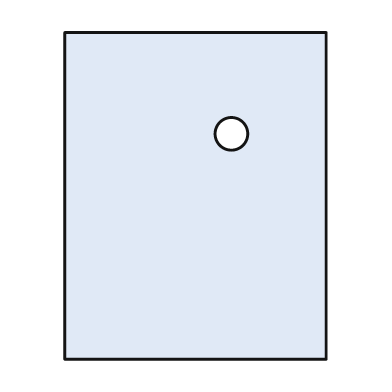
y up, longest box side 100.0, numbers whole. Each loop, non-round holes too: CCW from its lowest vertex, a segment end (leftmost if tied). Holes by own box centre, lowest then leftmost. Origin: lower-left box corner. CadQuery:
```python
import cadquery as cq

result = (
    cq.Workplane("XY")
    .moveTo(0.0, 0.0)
    .lineTo(80.0, 0.0)
    .lineTo(80.0, 100.0)
    .lineTo(0.0, 100.0)
    .close()
    .moveTo(51.0, 69.0)
    .circle(5.0)
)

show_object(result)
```